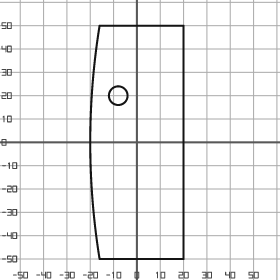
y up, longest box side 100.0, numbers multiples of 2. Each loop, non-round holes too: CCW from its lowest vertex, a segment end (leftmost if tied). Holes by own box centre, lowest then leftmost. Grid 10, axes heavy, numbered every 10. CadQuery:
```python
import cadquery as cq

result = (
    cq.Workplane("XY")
    .moveTo(-16.0, -50.0)
    .lineTo(20.0, -50.0)
    .lineTo(20.0, 50.0)
    .lineTo(-16.0, 50.0)
    .threePointArc((-20.0, 0.0), (-16.0, -50.0))
    .close()
    .moveTo(-8.0, 20.0)
    .circle(4.0)
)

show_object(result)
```